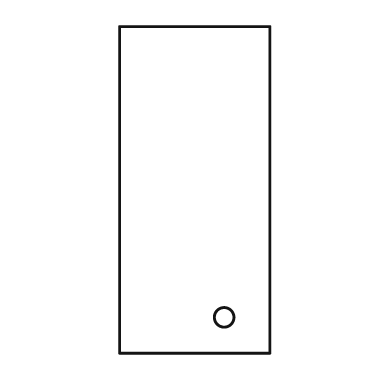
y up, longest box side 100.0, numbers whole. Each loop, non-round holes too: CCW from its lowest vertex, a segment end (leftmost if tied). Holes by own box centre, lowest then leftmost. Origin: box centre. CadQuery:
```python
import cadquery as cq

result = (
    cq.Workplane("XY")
    .moveTo(-23.0, -50.0)
    .lineTo(23.0, -50.0)
    .lineTo(23.0, 50.0)
    .lineTo(-23.0, 50.0)
    .close()
    .moveTo(9.0, -39.0)
    .circle(3.0)
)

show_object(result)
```